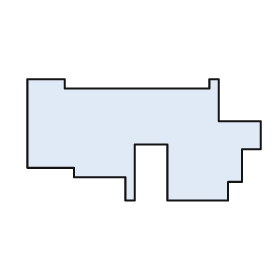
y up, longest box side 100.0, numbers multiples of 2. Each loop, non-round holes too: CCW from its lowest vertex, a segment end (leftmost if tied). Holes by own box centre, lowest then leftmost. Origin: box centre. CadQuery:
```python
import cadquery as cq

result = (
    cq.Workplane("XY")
    .moveTo(-8.0, -26.0)
    .lineTo(-4.0, -26.0)
    .lineTo(-4.0, -2.0)
    .lineTo(10.0, -2.0)
    .lineTo(10.0, -26.0)
    .lineTo(36.0, -26.0)
    .lineTo(36.0, -18.0)
    .lineTo(42.0, -18.0)
    .lineTo(42.0, -4.0)
    .lineTo(50.0, -4.0)
    .lineTo(50.0, 8.0)
    .lineTo(32.0, 8.0)
    .lineTo(32.0, 26.0)
    .lineTo(28.0, 26.0)
    .lineTo(28.0, 22.0)
    .lineTo(-34.0, 22.0)
    .lineTo(-34.0, 26.0)
    .lineTo(-50.0, 26.0)
    .lineTo(-50.0, -12.0)
    .lineTo(-30.0, -12.0)
    .lineTo(-30.0, -16.0)
    .lineTo(-8.0, -16.0)
    .close()
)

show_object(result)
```